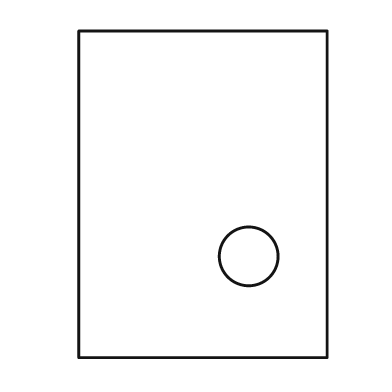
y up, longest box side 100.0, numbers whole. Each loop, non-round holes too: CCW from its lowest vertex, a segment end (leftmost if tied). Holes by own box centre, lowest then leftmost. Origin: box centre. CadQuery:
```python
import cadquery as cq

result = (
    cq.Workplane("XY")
    .moveTo(-38.0, -50.0)
    .lineTo(38.0, -50.0)
    .lineTo(38.0, 50.0)
    .lineTo(-38.0, 50.0)
    .close()
    .moveTo(14.0, -19.0)
    .circle(9.0)
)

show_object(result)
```